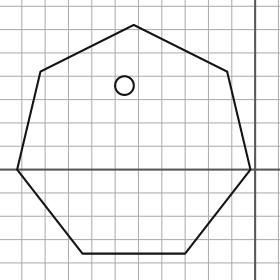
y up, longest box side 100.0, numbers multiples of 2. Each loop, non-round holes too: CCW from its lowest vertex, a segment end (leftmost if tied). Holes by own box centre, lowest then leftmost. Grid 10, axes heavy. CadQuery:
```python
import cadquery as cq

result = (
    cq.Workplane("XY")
    .moveTo(-74.0, -36.0)
    .lineTo(-30.0, -36.0)
    .lineTo(-2.0, 0.0)
    .lineTo(-12.0, 42.0)
    .lineTo(-52.0, 62.0)
    .lineTo(-92.0, 42.0)
    .lineTo(-102.0, 0.0)
    .close()
    .moveTo(-56.0, 36.0)
    .circle(4.0)
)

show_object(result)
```